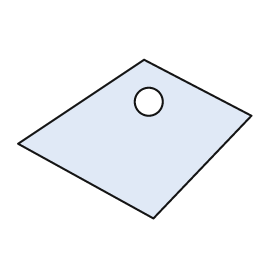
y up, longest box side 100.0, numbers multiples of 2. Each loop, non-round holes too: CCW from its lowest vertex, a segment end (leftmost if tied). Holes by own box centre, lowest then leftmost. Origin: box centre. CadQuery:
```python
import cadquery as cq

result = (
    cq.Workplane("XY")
    .moveTo(8.0, -34.0)
    .lineTo(50.0, 10.0)
    .lineTo(4.0, 34.0)
    .lineTo(-50.0, -2.0)
    .close()
    .moveTo(6.0, 16.0)
    .circle(6.0)
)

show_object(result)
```